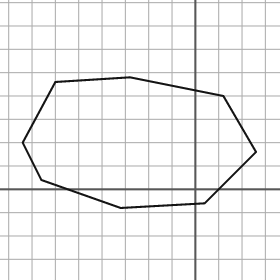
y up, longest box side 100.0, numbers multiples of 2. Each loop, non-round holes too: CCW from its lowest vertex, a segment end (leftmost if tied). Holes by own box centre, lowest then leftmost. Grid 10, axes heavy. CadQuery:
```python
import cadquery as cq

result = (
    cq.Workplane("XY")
    .moveTo(-32.0, -8.0)
    .lineTo(4.0, -6.0)
    .lineTo(26.0, 16.0)
    .lineTo(12.0, 40.0)
    .lineTo(-28.0, 48.0)
    .lineTo(-60.0, 46.0)
    .lineTo(-74.0, 20.0)
    .lineTo(-66.0, 4.0)
    .close()
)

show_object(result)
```